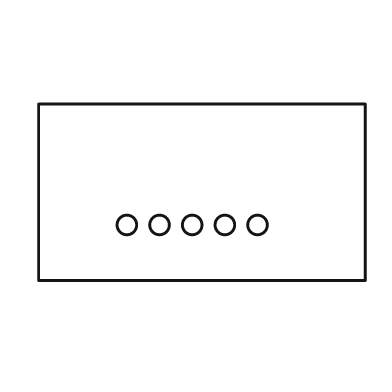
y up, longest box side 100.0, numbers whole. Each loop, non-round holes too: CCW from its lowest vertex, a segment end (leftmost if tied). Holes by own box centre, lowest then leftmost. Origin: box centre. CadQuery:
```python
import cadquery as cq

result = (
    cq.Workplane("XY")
    .moveTo(-50.0, -27.0)
    .lineTo(50.0, -27.0)
    .lineTo(50.0, 27.0)
    .lineTo(-50.0, 27.0)
    .close()
    .moveTo(-23.0, -10.0)
    .circle(3.0)
    .moveTo(-13.0, -10.0)
    .circle(3.0)
    .moveTo(-3.0, -10.0)
    .circle(3.0)
    .moveTo(7.0, -10.0)
    .circle(3.0)
    .moveTo(17.0, -10.0)
    .circle(3.0)
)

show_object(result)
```